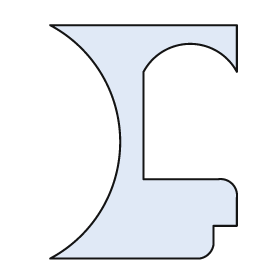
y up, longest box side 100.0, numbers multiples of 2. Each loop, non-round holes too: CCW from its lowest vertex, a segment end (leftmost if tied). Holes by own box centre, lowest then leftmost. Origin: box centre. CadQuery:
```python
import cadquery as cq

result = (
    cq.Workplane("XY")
    .moveTo(-40.0, -50.0)
    .lineTo(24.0, -50.0)
    .threePointArc((28.0, -48.0), (30.0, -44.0))
    .lineTo(30.0, -36.0)
    .lineTo(40.0, -36.0)
    .lineTo(40.0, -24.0)
    .threePointArc((38.0, -18.0), (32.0, -16.0))
    .lineTo(0.0, -16.0)
    .lineTo(0.0, 30.0)
    .threePointArc((20.0, 42.0), (40.0, 30.0))
    .lineTo(40.0, 50.0)
    .lineTo(-40.0, 50.0)
    .threePointArc((-10.0, 0.0), (-40.0, -50.0))
    .close()
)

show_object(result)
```